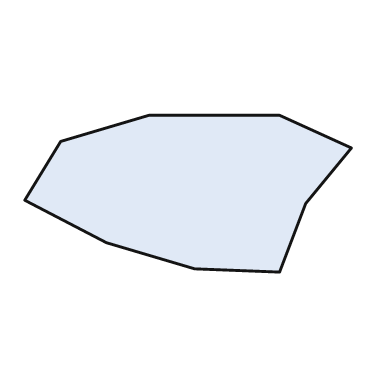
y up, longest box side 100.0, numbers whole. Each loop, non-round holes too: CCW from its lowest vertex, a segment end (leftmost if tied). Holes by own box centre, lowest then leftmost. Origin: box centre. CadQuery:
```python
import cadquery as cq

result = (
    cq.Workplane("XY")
    .moveTo(28.0, -24.0)
    .lineTo(36.0, -3.0)
    .lineTo(50.0, 14.0)
    .lineTo(28.0, 24.0)
    .lineTo(-12.0, 24.0)
    .lineTo(-39.0, 16.0)
    .lineTo(-50.0, -2.0)
    .lineTo(-25.0, -15.0)
    .lineTo(2.0, -23.0)
    .close()
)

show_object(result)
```